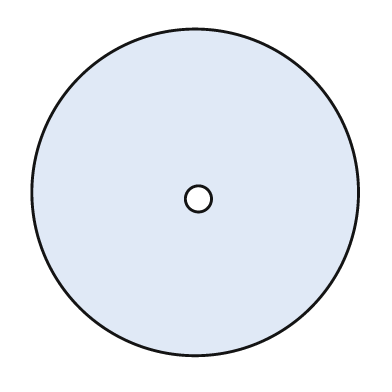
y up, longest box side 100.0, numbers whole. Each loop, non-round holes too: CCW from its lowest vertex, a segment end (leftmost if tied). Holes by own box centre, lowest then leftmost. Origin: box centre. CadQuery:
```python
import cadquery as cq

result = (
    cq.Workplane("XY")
    .moveTo(0.0, 0.0)
    .circle(50.0)
    .moveTo(1.0, -2.0)
    .circle(4.0)
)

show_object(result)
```